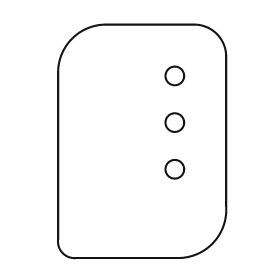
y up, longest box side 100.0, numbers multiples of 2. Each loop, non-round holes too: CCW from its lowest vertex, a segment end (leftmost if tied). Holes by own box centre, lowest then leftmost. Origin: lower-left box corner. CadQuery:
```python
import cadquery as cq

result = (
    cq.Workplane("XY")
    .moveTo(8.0, 0.0)
    .lineTo(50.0, 0.0)
    .threePointArc((66.0, 6.0), (72.0, 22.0))
    .lineTo(72.0, 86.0)
    .threePointArc((68.0, 96.0), (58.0, 100.0))
    .lineTo(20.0, 100.0)
    .threePointArc((6.0, 94.0), (0.0, 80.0))
    .lineTo(0.0, 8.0)
    .threePointArc((2.0, 2.0), (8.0, 0.0))
    .close()
    .moveTo(50.0, 38.0)
    .circle(4.0)
    .moveTo(50.0, 58.0)
    .circle(4.0)
    .moveTo(50.0, 78.0)
    .circle(4.0)
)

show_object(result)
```